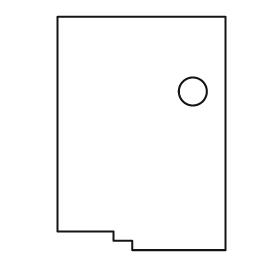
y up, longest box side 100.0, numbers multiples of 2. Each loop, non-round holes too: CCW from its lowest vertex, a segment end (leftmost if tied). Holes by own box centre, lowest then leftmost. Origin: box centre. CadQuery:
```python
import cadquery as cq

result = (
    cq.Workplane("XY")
    .moveTo(-4.0, -50.0)
    .lineTo(36.0, -50.0)
    .lineTo(36.0, 50.0)
    .lineTo(-36.0, 50.0)
    .lineTo(-36.0, -42.0)
    .lineTo(-12.0, -42.0)
    .lineTo(-12.0, -46.0)
    .lineTo(-4.0, -46.0)
    .close()
    .moveTo(22.0, 18.0)
    .circle(6.0)
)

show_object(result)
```